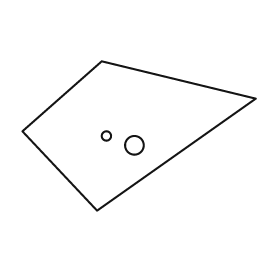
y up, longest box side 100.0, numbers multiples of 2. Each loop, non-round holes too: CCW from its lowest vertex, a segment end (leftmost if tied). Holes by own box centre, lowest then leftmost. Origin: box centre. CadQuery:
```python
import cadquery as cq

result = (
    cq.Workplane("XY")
    .moveTo(-18.0, -32.0)
    .lineTo(50.0, 16.0)
    .lineTo(-16.0, 32.0)
    .lineTo(-50.0, 2.0)
    .close()
    .moveTo(-2.0, -4.0)
    .circle(4.0)
    .moveTo(-14.0, 0.0)
    .circle(2.0)
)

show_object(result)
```